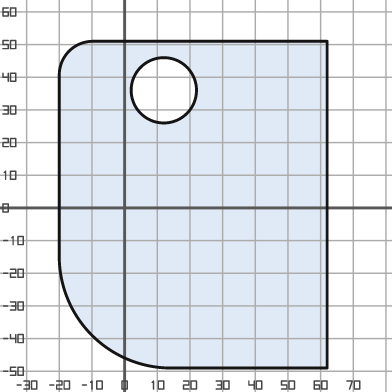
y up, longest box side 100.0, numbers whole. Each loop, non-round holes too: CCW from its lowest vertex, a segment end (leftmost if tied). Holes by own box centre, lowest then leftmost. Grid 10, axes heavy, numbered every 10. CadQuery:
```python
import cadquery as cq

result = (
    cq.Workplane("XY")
    .moveTo(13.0, -49.0)
    .lineTo(62.0, -49.0)
    .lineTo(62.0, 51.0)
    .lineTo(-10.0, 51.0)
    .threePointArc((-17.0, 48.0), (-20.0, 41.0))
    .lineTo(-20.0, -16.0)
    .threePointArc((-10.0, -39.0), (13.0, -49.0))
    .close()
    .moveTo(12.0, 36.0)
    .circle(10.0)
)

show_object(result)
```